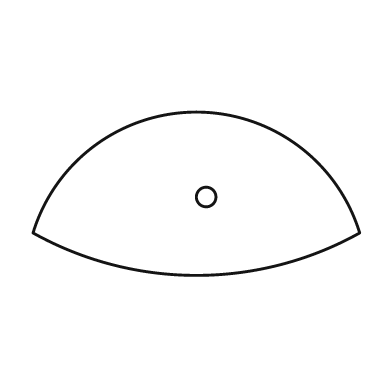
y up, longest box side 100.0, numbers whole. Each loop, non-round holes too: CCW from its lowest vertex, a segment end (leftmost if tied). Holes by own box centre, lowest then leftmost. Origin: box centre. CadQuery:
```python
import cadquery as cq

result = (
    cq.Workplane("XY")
    .moveTo(-50.0, -12.0)
    .threePointArc((0.0, -25.0), (50.0, -12.0))
    .threePointArc((0.0, 25.0), (-50.0, -12.0))
    .close()
    .moveTo(3.0, -1.0)
    .circle(3.0)
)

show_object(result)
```